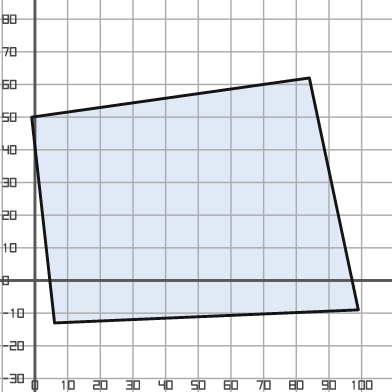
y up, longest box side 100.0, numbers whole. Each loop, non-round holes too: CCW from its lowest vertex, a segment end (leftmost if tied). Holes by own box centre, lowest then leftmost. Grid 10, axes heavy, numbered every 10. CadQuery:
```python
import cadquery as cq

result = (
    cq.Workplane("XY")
    .moveTo(6.0, -13.0)
    .lineTo(99.0, -9.0)
    .lineTo(84.0, 62.0)
    .lineTo(-1.0, 50.0)
    .close()
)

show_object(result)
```